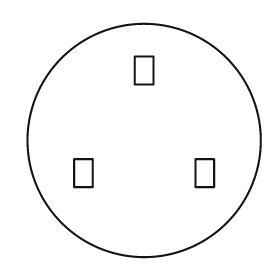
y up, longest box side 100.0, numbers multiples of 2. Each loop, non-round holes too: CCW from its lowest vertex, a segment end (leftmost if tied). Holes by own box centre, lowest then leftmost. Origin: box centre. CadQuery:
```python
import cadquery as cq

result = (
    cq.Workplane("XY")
    .moveTo(0.0, 0.0)
    .circle(50.0)
    .moveTo(-30.0, -20.0)
    .lineTo(-22.0, -20.0)
    .lineTo(-22.0, -8.0)
    .lineTo(-30.0, -8.0)
    .close()
    .moveTo(22.0, -20.0)
    .lineTo(30.0, -20.0)
    .lineTo(30.0, -8.0)
    .lineTo(22.0, -8.0)
    .close()
    .moveTo(-4.0, 24.0)
    .lineTo(4.0, 24.0)
    .lineTo(4.0, 36.0)
    .lineTo(-4.0, 36.0)
    .close()
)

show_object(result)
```